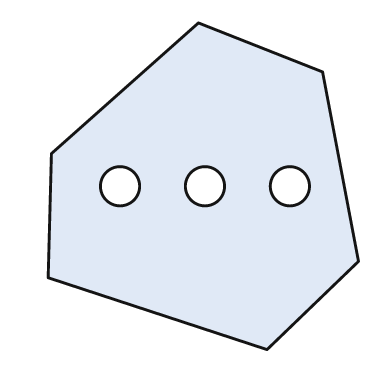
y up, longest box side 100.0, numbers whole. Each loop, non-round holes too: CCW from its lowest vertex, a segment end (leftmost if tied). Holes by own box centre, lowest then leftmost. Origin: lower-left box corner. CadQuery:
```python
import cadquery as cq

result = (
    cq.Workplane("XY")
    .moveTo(67.0, 0.0)
    .lineTo(95.0, 27.0)
    .lineTo(84.0, 85.0)
    .lineTo(46.0, 100.0)
    .lineTo(1.0, 60.0)
    .lineTo(0.0, 22.0)
    .close()
    .moveTo(22.0, 50.0)
    .circle(6.0)
    .moveTo(48.0, 50.0)
    .circle(6.0)
    .moveTo(74.0, 50.0)
    .circle(6.0)
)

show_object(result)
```